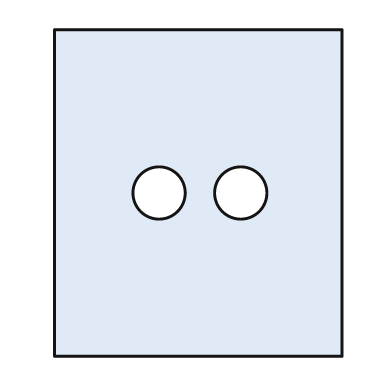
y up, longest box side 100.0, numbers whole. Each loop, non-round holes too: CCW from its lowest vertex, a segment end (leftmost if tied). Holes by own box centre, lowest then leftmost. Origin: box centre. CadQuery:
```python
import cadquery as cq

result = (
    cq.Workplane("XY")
    .moveTo(-44.0, -50.0)
    .lineTo(44.0, -50.0)
    .lineTo(44.0, 50.0)
    .lineTo(-44.0, 50.0)
    .close()
    .moveTo(-12.0, 0.0)
    .circle(8.0)
    .moveTo(13.0, 0.0)
    .circle(8.0)
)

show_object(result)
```